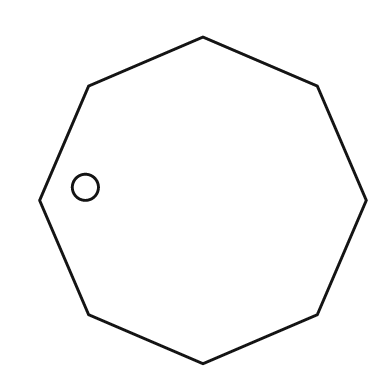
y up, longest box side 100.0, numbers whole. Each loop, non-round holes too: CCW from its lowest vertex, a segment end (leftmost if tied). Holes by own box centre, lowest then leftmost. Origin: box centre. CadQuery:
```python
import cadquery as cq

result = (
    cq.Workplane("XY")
    .moveTo(0.0, -50.0)
    .lineTo(35.0, -35.0)
    .lineTo(50.0, 0.0)
    .lineTo(35.0, 35.0)
    .lineTo(0.0, 50.0)
    .lineTo(-35.0, 35.0)
    .lineTo(-50.0, 0.0)
    .lineTo(-35.0, -35.0)
    .close()
    .moveTo(-36.0, 4.0)
    .circle(4.0)
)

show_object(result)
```